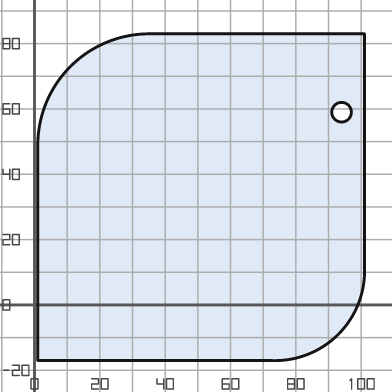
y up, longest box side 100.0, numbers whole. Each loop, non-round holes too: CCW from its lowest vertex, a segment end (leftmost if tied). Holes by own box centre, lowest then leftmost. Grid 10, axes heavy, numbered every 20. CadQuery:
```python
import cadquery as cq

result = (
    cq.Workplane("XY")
    .moveTo(1.0, -17.0)
    .lineTo(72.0, -17.0)
    .threePointArc((93.0, -9.0), (101.0, 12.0))
    .lineTo(101.0, 83.0)
    .lineTo(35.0, 83.0)
    .threePointArc((11.0, 73.0), (1.0, 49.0))
    .close()
    .moveTo(94.0, 59.0)
    .circle(3.0)
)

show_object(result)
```